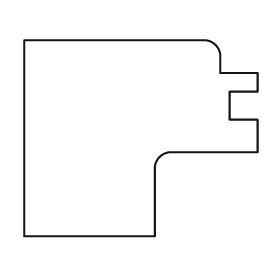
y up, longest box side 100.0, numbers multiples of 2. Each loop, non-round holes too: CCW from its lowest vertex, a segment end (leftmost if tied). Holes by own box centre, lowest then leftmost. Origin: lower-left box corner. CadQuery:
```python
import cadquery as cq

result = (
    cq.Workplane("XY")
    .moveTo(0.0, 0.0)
    .lineTo(56.0, 0.0)
    .lineTo(56.0, 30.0)
    .threePointArc((58.0, 34.0), (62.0, 36.0))
    .lineTo(100.0, 36.0)
    .lineTo(100.0, 50.0)
    .lineTo(88.0, 50.0)
    .lineTo(88.0, 62.0)
    .lineTo(100.0, 62.0)
    .lineTo(100.0, 70.0)
    .lineTo(84.0, 70.0)
    .lineTo(84.0, 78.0)
    .threePointArc((82.0, 82.0), (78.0, 84.0))
    .lineTo(0.0, 84.0)
    .close()
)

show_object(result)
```